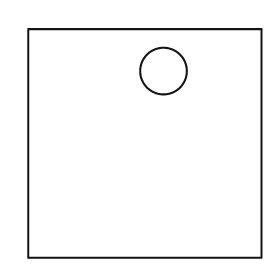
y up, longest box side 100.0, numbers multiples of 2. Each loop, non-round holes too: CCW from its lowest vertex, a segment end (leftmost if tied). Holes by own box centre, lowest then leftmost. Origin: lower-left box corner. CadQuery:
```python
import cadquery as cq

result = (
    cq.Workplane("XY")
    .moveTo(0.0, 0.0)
    .lineTo(100.0, 0.0)
    .lineTo(100.0, 98.0)
    .lineTo(0.0, 98.0)
    .close()
    .moveTo(58.0, 80.0)
    .circle(10.0)
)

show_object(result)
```